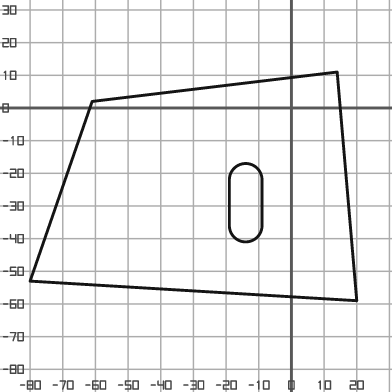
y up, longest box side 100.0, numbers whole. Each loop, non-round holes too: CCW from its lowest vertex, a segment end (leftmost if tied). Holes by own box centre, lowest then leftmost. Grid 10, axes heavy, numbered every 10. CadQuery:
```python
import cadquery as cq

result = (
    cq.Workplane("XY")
    .moveTo(20.0, -59.0)
    .lineTo(14.0, 11.0)
    .lineTo(-61.0, 2.0)
    .lineTo(-80.0, -53.0)
    .close()
    .moveTo(-19.0, -36.0)
    .threePointArc((-14.0, -41.0), (-9.0, -36.0))
    .lineTo(-9.0, -22.0)
    .threePointArc((-14.0, -17.0), (-19.0, -22.0))
    .close()
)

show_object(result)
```